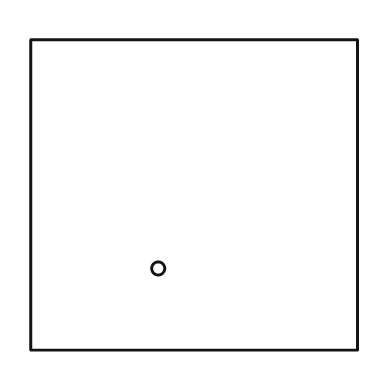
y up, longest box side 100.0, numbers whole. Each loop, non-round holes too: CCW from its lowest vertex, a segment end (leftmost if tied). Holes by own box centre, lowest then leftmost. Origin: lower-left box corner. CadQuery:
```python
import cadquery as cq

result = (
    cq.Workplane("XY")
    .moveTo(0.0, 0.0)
    .lineTo(100.0, 0.0)
    .lineTo(100.0, 95.0)
    .lineTo(0.0, 95.0)
    .close()
    .moveTo(39.0, 25.0)
    .circle(2.0)
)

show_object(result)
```